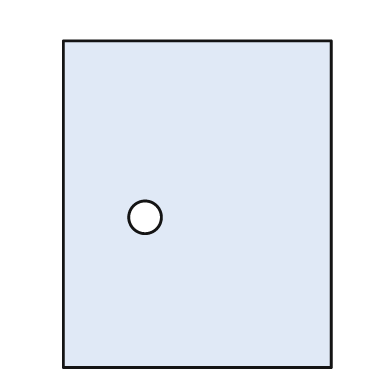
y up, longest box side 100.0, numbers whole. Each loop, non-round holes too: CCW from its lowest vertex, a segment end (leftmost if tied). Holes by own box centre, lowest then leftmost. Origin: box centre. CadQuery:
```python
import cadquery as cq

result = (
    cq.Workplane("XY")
    .moveTo(-41.0, -50.0)
    .lineTo(41.0, -50.0)
    .lineTo(41.0, 50.0)
    .lineTo(-41.0, 50.0)
    .close()
    .moveTo(-16.0, -4.0)
    .circle(5.0)
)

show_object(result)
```